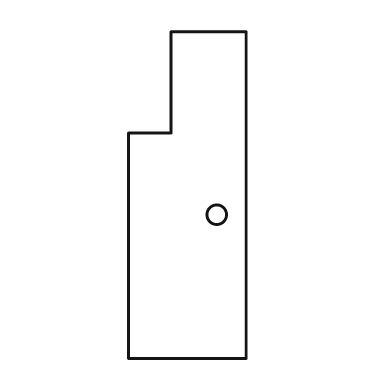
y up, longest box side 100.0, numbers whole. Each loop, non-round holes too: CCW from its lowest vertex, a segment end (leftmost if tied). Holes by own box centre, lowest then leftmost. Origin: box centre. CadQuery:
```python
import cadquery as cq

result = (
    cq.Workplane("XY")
    .moveTo(-18.0, -50.0)
    .lineTo(18.0, -50.0)
    .lineTo(18.0, 50.0)
    .lineTo(-5.0, 50.0)
    .lineTo(-5.0, 19.0)
    .lineTo(-18.0, 19.0)
    .close()
    .moveTo(9.0, -6.0)
    .circle(3.0)
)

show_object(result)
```